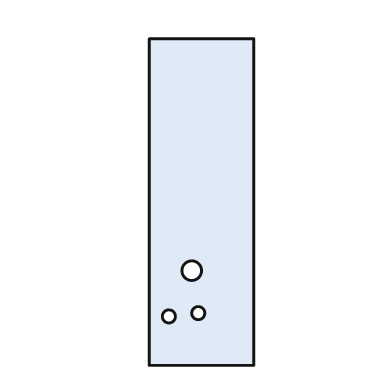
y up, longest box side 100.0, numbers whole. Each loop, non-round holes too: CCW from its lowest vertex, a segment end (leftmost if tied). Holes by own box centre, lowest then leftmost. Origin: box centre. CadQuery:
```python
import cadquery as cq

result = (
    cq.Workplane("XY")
    .moveTo(-16.0, -50.0)
    .lineTo(16.0, -50.0)
    .lineTo(16.0, 50.0)
    .lineTo(-16.0, 50.0)
    .close()
    .moveTo(-10.0, -35.0)
    .circle(2.0)
    .moveTo(-1.0, -34.0)
    .circle(2.0)
    .moveTo(-3.0, -21.0)
    .circle(3.0)
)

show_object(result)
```